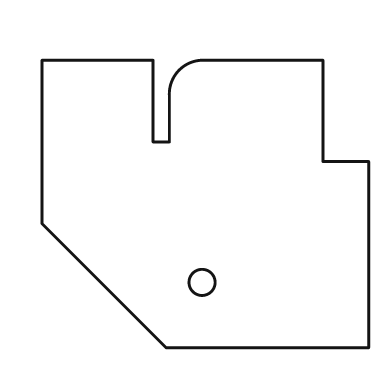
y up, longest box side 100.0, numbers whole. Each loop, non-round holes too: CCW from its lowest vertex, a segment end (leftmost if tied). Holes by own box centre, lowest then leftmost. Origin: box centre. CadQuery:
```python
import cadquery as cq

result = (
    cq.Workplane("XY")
    .moveTo(-12.0, -44.0)
    .lineTo(50.0, -44.0)
    .lineTo(50.0, 13.0)
    .lineTo(36.0, 13.0)
    .lineTo(36.0, 44.0)
    .lineTo(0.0, 44.0)
    .threePointArc((-8.0, 41.0), (-11.0, 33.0))
    .lineTo(-11.0, 19.0)
    .lineTo(-16.0, 19.0)
    .lineTo(-16.0, 44.0)
    .lineTo(-50.0, 44.0)
    .lineTo(-50.0, -6.0)
    .close()
    .moveTo(-1.0, -24.0)
    .circle(4.0)
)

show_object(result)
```